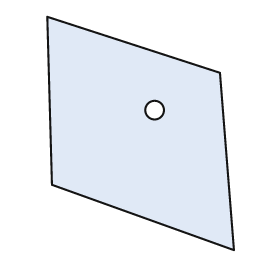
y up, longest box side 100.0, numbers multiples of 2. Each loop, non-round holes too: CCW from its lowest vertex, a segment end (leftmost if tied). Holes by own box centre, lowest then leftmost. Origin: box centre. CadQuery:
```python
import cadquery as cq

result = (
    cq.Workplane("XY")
    .moveTo(40.0, -50.0)
    .lineTo(34.0, 26.0)
    .lineTo(-40.0, 50.0)
    .lineTo(-38.0, -22.0)
    .close()
    .moveTo(6.0, 10.0)
    .circle(4.0)
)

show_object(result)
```